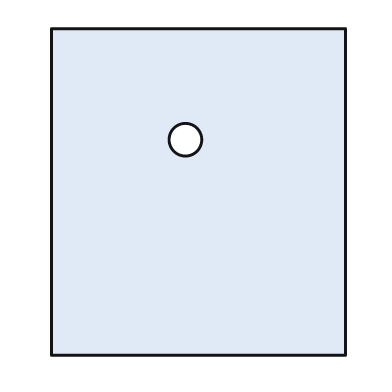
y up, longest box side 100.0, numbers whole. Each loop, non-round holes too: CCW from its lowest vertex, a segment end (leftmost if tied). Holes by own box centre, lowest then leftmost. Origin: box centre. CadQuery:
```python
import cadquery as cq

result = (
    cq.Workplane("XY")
    .moveTo(-45.0, -50.0)
    .lineTo(45.0, -50.0)
    .lineTo(45.0, 50.0)
    .lineTo(-45.0, 50.0)
    .close()
    .moveTo(-4.0, 16.0)
    .circle(5.0)
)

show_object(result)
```